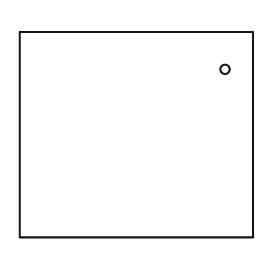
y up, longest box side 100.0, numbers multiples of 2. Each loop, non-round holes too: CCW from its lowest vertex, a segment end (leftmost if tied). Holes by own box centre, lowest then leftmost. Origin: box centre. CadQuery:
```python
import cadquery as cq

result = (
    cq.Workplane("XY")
    .moveTo(-50.0, -44.0)
    .lineTo(50.0, -44.0)
    .lineTo(50.0, 44.0)
    .lineTo(-50.0, 44.0)
    .close()
    .moveTo(38.0, 28.0)
    .circle(2.0)
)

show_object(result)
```